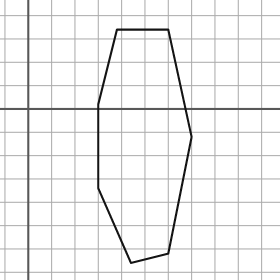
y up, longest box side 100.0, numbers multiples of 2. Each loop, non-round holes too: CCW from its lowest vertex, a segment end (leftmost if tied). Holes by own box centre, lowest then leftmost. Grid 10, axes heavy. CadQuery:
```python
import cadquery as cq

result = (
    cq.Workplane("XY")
    .moveTo(44.0, -66.0)
    .lineTo(60.0, -62.0)
    .lineTo(70.0, -12.0)
    .lineTo(60.0, 34.0)
    .lineTo(38.0, 34.0)
    .lineTo(30.0, 2.0)
    .lineTo(30.0, -34.0)
    .close()
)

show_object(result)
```